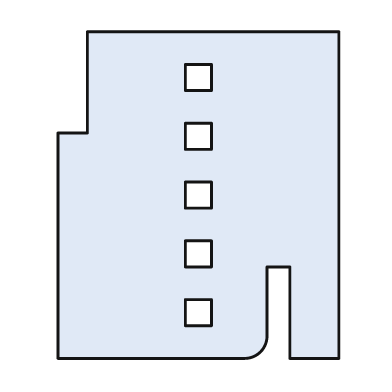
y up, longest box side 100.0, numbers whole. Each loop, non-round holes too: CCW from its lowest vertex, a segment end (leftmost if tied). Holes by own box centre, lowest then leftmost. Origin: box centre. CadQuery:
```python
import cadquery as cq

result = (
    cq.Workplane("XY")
    .moveTo(-43.0, -50.0)
    .lineTo(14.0, -50.0)
    .threePointArc((19.0, -48.0), (21.0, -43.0))
    .lineTo(21.0, -22.0)
    .lineTo(28.0, -22.0)
    .lineTo(28.0, -50.0)
    .lineTo(43.0, -50.0)
    .lineTo(43.0, 50.0)
    .lineTo(-34.0, 50.0)
    .lineTo(-34.0, 19.0)
    .lineTo(-43.0, 19.0)
    .close()
    .moveTo(-4.0, -40.0)
    .lineTo(4.0, -40.0)
    .lineTo(4.0, -32.0)
    .lineTo(-4.0, -32.0)
    .close()
    .moveTo(-4.0, -22.0)
    .lineTo(4.0, -22.0)
    .lineTo(4.0, -14.0)
    .lineTo(-4.0, -14.0)
    .close()
    .moveTo(-4.0, -4.0)
    .lineTo(4.0, -4.0)
    .lineTo(4.0, 4.0)
    .lineTo(-4.0, 4.0)
    .close()
    .moveTo(-4.0, 14.0)
    .lineTo(4.0, 14.0)
    .lineTo(4.0, 22.0)
    .lineTo(-4.0, 22.0)
    .close()
    .moveTo(-4.0, 32.0)
    .lineTo(4.0, 32.0)
    .lineTo(4.0, 40.0)
    .lineTo(-4.0, 40.0)
    .close()
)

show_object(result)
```